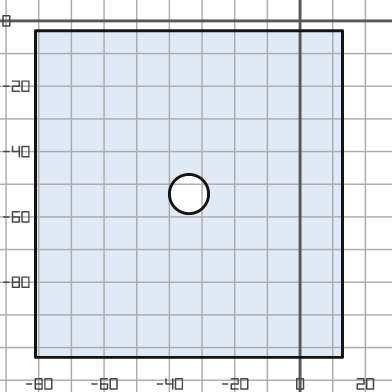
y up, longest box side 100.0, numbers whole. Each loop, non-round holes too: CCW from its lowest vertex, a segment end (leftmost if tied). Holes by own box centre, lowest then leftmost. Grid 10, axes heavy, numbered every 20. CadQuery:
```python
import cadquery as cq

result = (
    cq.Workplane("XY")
    .moveTo(-81.0, -103.0)
    .lineTo(13.0, -103.0)
    .lineTo(13.0, -3.0)
    .lineTo(-81.0, -3.0)
    .close()
    .moveTo(-34.0, -53.0)
    .circle(6.0)
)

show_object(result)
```